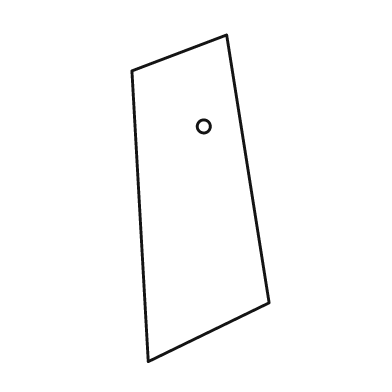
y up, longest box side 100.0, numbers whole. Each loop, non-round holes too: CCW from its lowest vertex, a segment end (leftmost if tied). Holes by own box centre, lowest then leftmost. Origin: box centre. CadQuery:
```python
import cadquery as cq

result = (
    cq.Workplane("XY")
    .moveTo(-16.0, -50.0)
    .lineTo(21.0, -32.0)
    .lineTo(8.0, 50.0)
    .lineTo(-21.0, 39.0)
    .close()
    .moveTo(1.0, 22.0)
    .circle(2.0)
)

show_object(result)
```